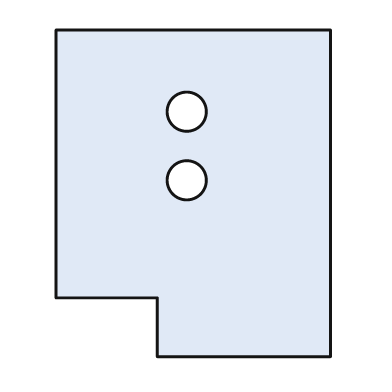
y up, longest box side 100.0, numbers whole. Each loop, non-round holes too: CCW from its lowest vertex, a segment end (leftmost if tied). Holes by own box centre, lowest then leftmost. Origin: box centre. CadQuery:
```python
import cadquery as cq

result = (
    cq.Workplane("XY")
    .moveTo(-11.0, -50.0)
    .lineTo(42.0, -50.0)
    .lineTo(42.0, 50.0)
    .lineTo(-42.0, 50.0)
    .lineTo(-42.0, -32.0)
    .lineTo(-11.0, -32.0)
    .close()
    .moveTo(-2.0, 4.0)
    .circle(6.0)
    .moveTo(-2.0, 25.0)
    .circle(6.0)
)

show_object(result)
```